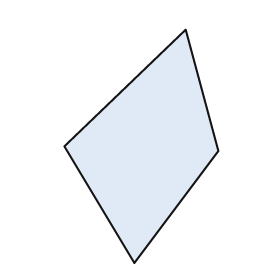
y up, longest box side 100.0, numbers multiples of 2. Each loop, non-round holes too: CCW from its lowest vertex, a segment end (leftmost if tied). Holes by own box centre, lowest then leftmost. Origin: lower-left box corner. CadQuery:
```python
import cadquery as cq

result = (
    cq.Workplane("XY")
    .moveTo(30.0, 0.0)
    .lineTo(66.0, 48.0)
    .lineTo(52.0, 100.0)
    .lineTo(0.0, 50.0)
    .close()
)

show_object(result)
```